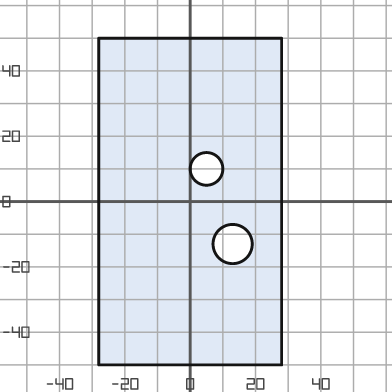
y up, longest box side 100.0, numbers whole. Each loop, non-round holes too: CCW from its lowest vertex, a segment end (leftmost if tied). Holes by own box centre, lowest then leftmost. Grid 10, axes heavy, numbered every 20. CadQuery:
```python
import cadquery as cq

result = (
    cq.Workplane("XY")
    .moveTo(-28.0, -50.0)
    .lineTo(28.0, -50.0)
    .lineTo(28.0, 50.0)
    .lineTo(-28.0, 50.0)
    .close()
    .moveTo(13.0, -13.0)
    .circle(6.0)
    .moveTo(5.0, 10.0)
    .circle(5.0)
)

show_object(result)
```